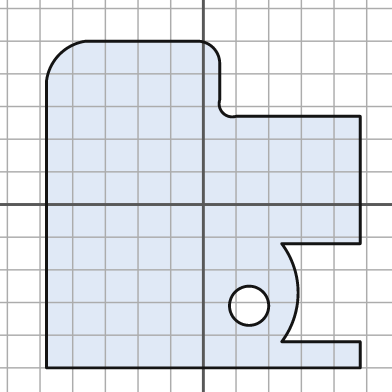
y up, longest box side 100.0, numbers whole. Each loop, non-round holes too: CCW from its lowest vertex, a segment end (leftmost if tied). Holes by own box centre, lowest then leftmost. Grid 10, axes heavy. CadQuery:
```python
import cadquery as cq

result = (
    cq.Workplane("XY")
    .moveTo(-48.0, -50.0)
    .lineTo(48.0, -50.0)
    .lineTo(48.0, -42.0)
    .lineTo(24.0, -42.0)
    .threePointArc((29.0, -27.0), (24.0, -12.0))
    .lineTo(48.0, -12.0)
    .lineTo(48.0, 27.0)
    .lineTo(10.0, 27.0)
    .threePointArc((6.0, 28.0), (5.0, 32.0))
    .lineTo(5.0, 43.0)
    .threePointArc((3.0, 48.0), (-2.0, 50.0))
    .lineTo(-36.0, 50.0)
    .threePointArc((-44.0, 46.0), (-48.0, 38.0))
    .close()
    .moveTo(14.0, -31.0)
    .circle(6.0)
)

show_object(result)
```